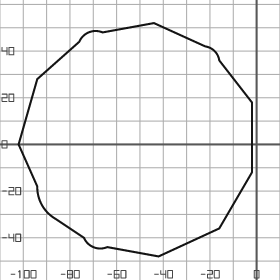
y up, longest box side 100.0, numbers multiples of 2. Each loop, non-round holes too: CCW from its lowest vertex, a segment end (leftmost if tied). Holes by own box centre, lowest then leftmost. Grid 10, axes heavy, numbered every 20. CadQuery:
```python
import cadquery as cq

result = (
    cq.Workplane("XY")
    .moveTo(-42.0, -48.0)
    .lineTo(-16.0, -36.0)
    .lineTo(-2.0, -12.0)
    .lineTo(-2.0, 18.0)
    .lineTo(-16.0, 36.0)
    .threePointArc((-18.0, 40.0), (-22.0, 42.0))
    .lineTo(-44.0, 52.0)
    .lineTo(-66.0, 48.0)
    .threePointArc((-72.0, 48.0), (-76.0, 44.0))
    .lineTo(-94.0, 28.0)
    .lineTo(-102.0, 0.0)
    .lineTo(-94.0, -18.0)
    .threePointArc((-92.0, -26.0), (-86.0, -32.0))
    .lineTo(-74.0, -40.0)
    .threePointArc((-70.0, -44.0), (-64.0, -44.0))
    .close()
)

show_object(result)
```